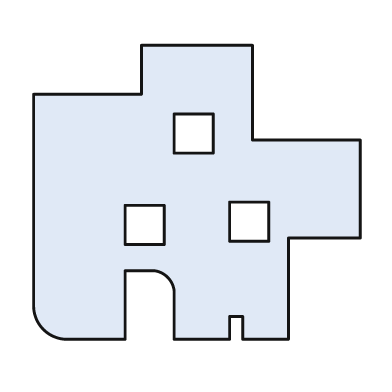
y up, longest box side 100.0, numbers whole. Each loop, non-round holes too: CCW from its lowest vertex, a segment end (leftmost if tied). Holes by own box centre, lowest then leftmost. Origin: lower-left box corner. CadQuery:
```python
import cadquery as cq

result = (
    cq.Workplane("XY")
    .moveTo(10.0, 0.0)
    .lineTo(28.0, 0.0)
    .lineTo(28.0, 21.0)
    .lineTo(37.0, 21.0)
    .threePointArc((41.0, 19.0), (43.0, 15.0))
    .lineTo(43.0, 0.0)
    .lineTo(60.0, 0.0)
    .lineTo(60.0, 7.0)
    .lineTo(64.0, 7.0)
    .lineTo(64.0, 0.0)
    .lineTo(78.0, 0.0)
    .lineTo(78.0, 31.0)
    .lineTo(100.0, 31.0)
    .lineTo(100.0, 61.0)
    .lineTo(67.0, 61.0)
    .lineTo(67.0, 90.0)
    .lineTo(33.0, 90.0)
    .lineTo(33.0, 75.0)
    .lineTo(0.0, 75.0)
    .lineTo(0.0, 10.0)
    .threePointArc((3.0, 3.0), (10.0, 0.0))
    .close()
    .moveTo(28.0, 29.0)
    .lineTo(40.0, 29.0)
    .lineTo(40.0, 41.0)
    .lineTo(28.0, 41.0)
    .close()
    .moveTo(60.0, 30.0)
    .lineTo(72.0, 30.0)
    .lineTo(72.0, 42.0)
    .lineTo(60.0, 42.0)
    .close()
    .moveTo(43.0, 57.0)
    .lineTo(55.0, 57.0)
    .lineTo(55.0, 69.0)
    .lineTo(43.0, 69.0)
    .close()
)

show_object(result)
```